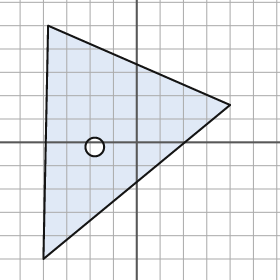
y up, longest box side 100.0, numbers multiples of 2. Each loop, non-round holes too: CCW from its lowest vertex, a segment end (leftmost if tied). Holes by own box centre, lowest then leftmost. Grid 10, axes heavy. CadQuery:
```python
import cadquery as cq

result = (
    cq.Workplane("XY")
    .moveTo(-40.0, -50.0)
    .lineTo(40.0, 16.0)
    .lineTo(-38.0, 50.0)
    .close()
    .moveTo(-18.0, -2.0)
    .circle(4.0)
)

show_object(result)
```